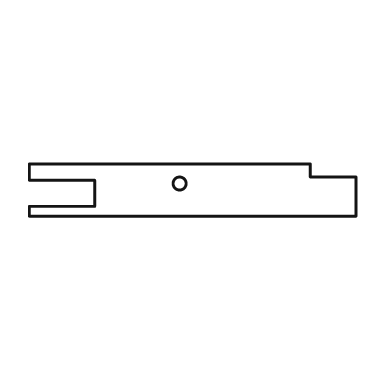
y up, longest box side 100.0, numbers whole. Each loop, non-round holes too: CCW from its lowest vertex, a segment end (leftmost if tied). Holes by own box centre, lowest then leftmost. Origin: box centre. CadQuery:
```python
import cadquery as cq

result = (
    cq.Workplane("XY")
    .moveTo(-50.0, -8.0)
    .lineTo(50.0, -8.0)
    .lineTo(50.0, 4.0)
    .lineTo(36.0, 4.0)
    .lineTo(36.0, 8.0)
    .lineTo(-50.0, 8.0)
    .lineTo(-50.0, 3.0)
    .lineTo(-30.0, 3.0)
    .lineTo(-30.0, -5.0)
    .lineTo(-50.0, -5.0)
    .close()
    .moveTo(-4.0, 2.0)
    .circle(2.0)
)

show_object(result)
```